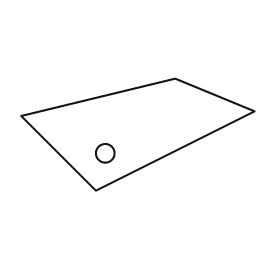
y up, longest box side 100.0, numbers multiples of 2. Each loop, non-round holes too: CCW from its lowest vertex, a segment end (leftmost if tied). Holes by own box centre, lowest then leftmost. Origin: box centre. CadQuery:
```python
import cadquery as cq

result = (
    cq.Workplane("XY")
    .moveTo(-18.0, -24.0)
    .lineTo(50.0, 10.0)
    .lineTo(16.0, 24.0)
    .lineTo(-50.0, 8.0)
    .close()
    .moveTo(-14.0, -8.0)
    .circle(4.0)
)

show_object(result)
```